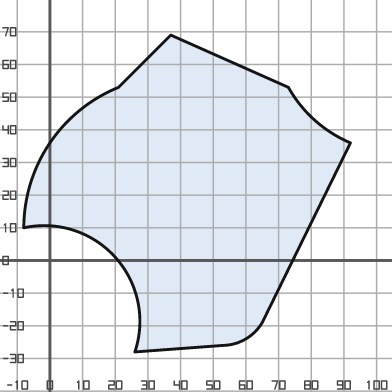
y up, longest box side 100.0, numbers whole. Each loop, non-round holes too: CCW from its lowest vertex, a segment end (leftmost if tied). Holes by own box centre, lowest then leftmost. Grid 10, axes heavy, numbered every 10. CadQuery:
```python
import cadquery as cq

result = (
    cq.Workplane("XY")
    .moveTo(26.0, -28.0)
    .lineTo(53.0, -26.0)
    .threePointArc((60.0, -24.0), (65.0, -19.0))
    .lineTo(92.0, 36.0)
    .threePointArc((81.0, 43.0), (73.0, 53.0))
    .lineTo(37.0, 69.0)
    .lineTo(21.0, 53.0)
    .threePointArc((0.0, 36.0), (-8.0, 10.0))
    .threePointArc((20.0, 1.0), (26.0, -28.0))
    .close()
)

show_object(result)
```